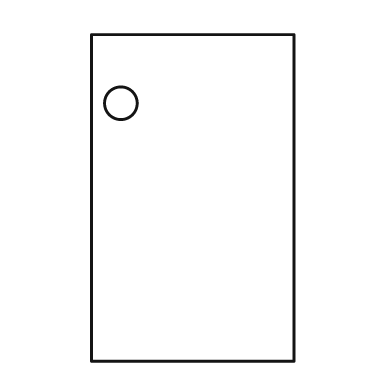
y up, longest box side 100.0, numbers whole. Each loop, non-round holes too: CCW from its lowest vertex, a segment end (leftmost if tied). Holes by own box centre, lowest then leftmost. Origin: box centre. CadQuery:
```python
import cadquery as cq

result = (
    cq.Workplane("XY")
    .moveTo(-31.0, -50.0)
    .lineTo(31.0, -50.0)
    .lineTo(31.0, 50.0)
    .lineTo(-31.0, 50.0)
    .close()
    .moveTo(-22.0, 29.0)
    .circle(5.0)
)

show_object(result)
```